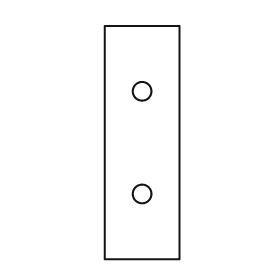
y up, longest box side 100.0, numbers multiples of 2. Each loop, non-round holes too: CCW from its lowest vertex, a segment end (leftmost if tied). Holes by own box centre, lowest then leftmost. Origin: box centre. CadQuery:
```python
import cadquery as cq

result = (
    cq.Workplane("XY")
    .moveTo(-16.0, -50.0)
    .lineTo(16.0, -50.0)
    .lineTo(16.0, 50.0)
    .lineTo(-16.0, 50.0)
    .close()
    .moveTo(0.0, -22.0)
    .circle(4.0)
    .moveTo(0.0, 22.0)
    .circle(4.0)
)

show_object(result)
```